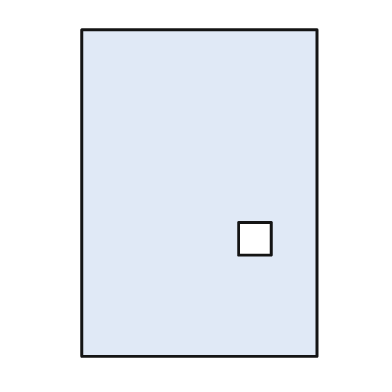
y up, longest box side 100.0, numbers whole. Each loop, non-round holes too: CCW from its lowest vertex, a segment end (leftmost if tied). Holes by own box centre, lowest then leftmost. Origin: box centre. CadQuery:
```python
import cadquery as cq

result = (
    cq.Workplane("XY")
    .moveTo(-36.0, -50.0)
    .lineTo(36.0, -50.0)
    .lineTo(36.0, 50.0)
    .lineTo(-36.0, 50.0)
    .close()
    .moveTo(12.0, -19.0)
    .lineTo(22.0, -19.0)
    .lineTo(22.0, -9.0)
    .lineTo(12.0, -9.0)
    .close()
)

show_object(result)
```